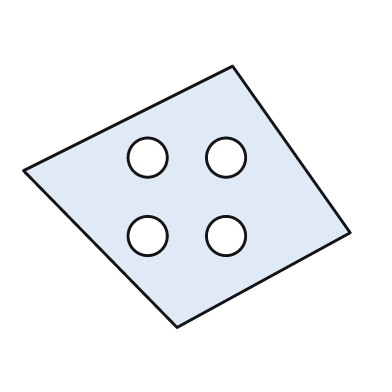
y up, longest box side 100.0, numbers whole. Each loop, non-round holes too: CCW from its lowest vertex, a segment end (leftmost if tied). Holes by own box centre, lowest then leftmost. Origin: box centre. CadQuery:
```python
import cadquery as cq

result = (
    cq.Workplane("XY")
    .moveTo(-3.0, -40.0)
    .lineTo(50.0, -11.0)
    .lineTo(14.0, 40.0)
    .lineTo(-50.0, 8.0)
    .close()
    .moveTo(-12.0, -12.0)
    .circle(6.0)
    .moveTo(12.0, -12.0)
    .circle(6.0)
    .moveTo(-12.0, 12.0)
    .circle(6.0)
    .moveTo(12.0, 12.0)
    .circle(6.0)
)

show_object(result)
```